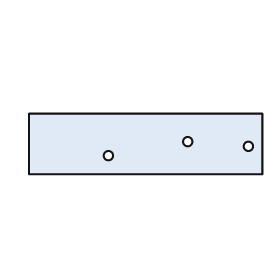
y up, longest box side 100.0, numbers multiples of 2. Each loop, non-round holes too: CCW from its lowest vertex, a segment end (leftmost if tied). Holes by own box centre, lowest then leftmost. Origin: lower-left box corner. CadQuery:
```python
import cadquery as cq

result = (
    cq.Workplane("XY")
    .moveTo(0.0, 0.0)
    .lineTo(100.0, 0.0)
    .lineTo(100.0, 26.0)
    .lineTo(0.0, 26.0)
    .close()
    .moveTo(34.0, 8.0)
    .circle(2.0)
    .moveTo(94.0, 12.0)
    .circle(2.0)
    .moveTo(68.0, 14.0)
    .circle(2.0)
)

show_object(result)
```